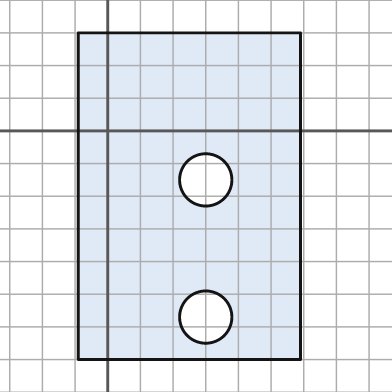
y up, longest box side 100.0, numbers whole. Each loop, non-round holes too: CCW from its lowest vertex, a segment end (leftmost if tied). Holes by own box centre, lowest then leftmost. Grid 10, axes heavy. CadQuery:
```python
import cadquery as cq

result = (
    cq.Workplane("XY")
    .moveTo(-9.0, -70.0)
    .lineTo(59.0, -70.0)
    .lineTo(59.0, 30.0)
    .lineTo(-9.0, 30.0)
    .close()
    .moveTo(30.0, -57.0)
    .circle(8.0)
    .moveTo(30.0, -15.0)
    .circle(8.0)
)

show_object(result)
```